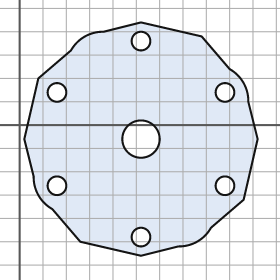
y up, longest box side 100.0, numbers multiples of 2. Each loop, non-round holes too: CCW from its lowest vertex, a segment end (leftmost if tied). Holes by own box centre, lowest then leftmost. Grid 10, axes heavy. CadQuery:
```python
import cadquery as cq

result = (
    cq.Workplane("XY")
    .moveTo(52.0, -56.0)
    .lineTo(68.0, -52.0)
    .threePointArc((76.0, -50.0), (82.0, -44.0))
    .lineTo(96.0, -32.0)
    .lineTo(102.0, -6.0)
    .lineTo(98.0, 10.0)
    .threePointArc((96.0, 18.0), (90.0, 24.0))
    .lineTo(78.0, 38.0)
    .lineTo(52.0, 44.0)
    .lineTo(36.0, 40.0)
    .threePointArc((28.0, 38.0), (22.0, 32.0))
    .lineTo(8.0, 20.0)
    .lineTo(2.0, -6.0)
    .lineTo(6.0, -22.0)
    .threePointArc((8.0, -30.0), (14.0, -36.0))
    .lineTo(26.0, -50.0)
    .close()
    .moveTo(52.0, -48.0)
    .circle(4.0)
    .moveTo(16.0, -26.0)
    .circle(4.0)
    .moveTo(88.0, -26.0)
    .circle(4.0)
    .moveTo(52.0, -6.0)
    .circle(8.0)
    .moveTo(16.0, 14.0)
    .circle(4.0)
    .moveTo(88.0, 14.0)
    .circle(4.0)
    .moveTo(52.0, 36.0)
    .circle(4.0)
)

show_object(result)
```